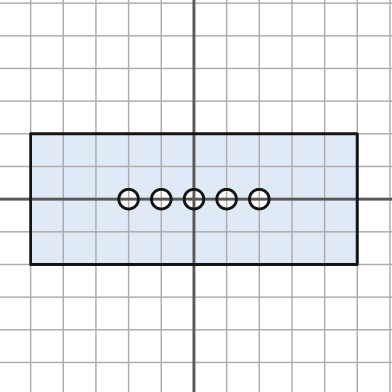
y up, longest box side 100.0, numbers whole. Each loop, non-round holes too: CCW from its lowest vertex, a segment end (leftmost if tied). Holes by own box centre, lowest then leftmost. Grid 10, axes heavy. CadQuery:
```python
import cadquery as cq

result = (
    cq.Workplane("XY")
    .moveTo(-50.0, -20.0)
    .lineTo(50.0, -20.0)
    .lineTo(50.0, 20.0)
    .lineTo(-50.0, 20.0)
    .close()
    .moveTo(-20.0, 0.0)
    .circle(3.0)
    .moveTo(-10.0, 0.0)
    .circle(3.0)
    .moveTo(0.0, 0.0)
    .circle(3.0)
    .moveTo(10.0, 0.0)
    .circle(3.0)
    .moveTo(20.0, 0.0)
    .circle(3.0)
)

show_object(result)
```